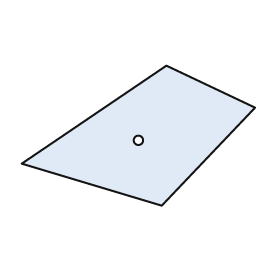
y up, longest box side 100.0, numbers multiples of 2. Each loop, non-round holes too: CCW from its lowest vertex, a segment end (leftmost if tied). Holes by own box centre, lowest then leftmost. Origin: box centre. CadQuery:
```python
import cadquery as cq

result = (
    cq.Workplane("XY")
    .moveTo(10.0, -30.0)
    .lineTo(50.0, 12.0)
    .lineTo(12.0, 30.0)
    .lineTo(-50.0, -12.0)
    .close()
    .moveTo(0.0, -2.0)
    .circle(2.0)
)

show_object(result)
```